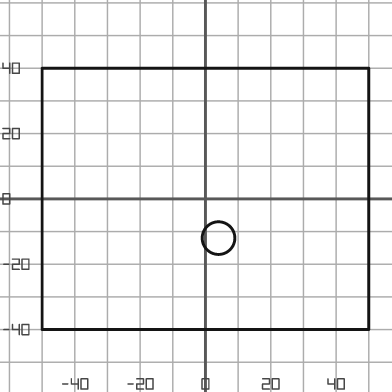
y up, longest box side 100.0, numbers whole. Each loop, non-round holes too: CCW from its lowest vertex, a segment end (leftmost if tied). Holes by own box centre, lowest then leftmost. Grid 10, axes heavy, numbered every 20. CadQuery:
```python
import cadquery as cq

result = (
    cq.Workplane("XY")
    .moveTo(-50.0, -40.0)
    .lineTo(50.0, -40.0)
    .lineTo(50.0, 40.0)
    .lineTo(-50.0, 40.0)
    .close()
    .moveTo(4.0, -12.0)
    .circle(5.0)
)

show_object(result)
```